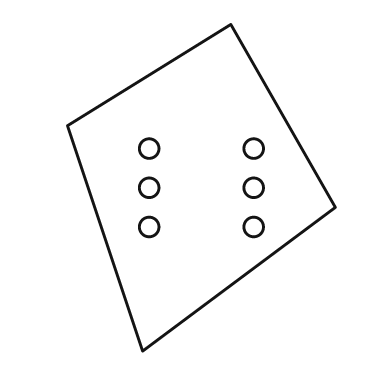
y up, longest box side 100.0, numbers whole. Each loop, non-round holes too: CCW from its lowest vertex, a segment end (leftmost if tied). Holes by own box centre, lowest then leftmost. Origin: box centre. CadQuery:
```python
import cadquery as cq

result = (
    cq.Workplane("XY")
    .moveTo(-18.0, -50.0)
    .lineTo(41.0, -6.0)
    .lineTo(9.0, 50.0)
    .lineTo(-41.0, 19.0)
    .close()
    .moveTo(-16.0, -12.0)
    .circle(3.0)
    .moveTo(16.0, -12.0)
    .circle(3.0)
    .moveTo(-16.0, 0.0)
    .circle(3.0)
    .moveTo(16.0, 0.0)
    .circle(3.0)
    .moveTo(-16.0, 12.0)
    .circle(3.0)
    .moveTo(16.0, 12.0)
    .circle(3.0)
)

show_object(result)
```